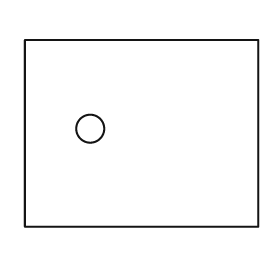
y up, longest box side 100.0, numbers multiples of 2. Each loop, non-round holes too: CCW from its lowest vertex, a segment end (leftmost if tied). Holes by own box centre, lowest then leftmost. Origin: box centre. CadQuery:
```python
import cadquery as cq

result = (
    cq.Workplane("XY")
    .moveTo(-50.0, -40.0)
    .lineTo(50.0, -40.0)
    .lineTo(50.0, 40.0)
    .lineTo(-50.0, 40.0)
    .close()
    .moveTo(-22.0, 2.0)
    .circle(6.0)
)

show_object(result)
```